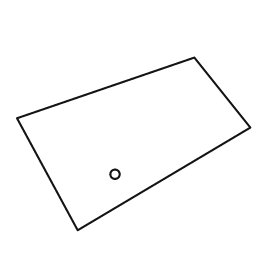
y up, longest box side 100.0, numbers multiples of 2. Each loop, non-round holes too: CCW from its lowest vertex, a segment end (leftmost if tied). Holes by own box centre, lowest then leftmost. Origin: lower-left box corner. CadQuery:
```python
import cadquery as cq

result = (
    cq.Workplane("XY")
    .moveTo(26.0, 0.0)
    .lineTo(100.0, 44.0)
    .lineTo(76.0, 74.0)
    .lineTo(0.0, 48.0)
    .close()
    .moveTo(42.0, 24.0)
    .circle(2.0)
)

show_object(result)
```